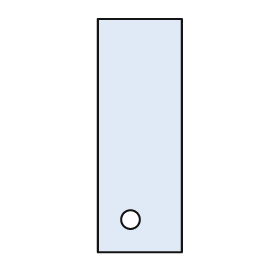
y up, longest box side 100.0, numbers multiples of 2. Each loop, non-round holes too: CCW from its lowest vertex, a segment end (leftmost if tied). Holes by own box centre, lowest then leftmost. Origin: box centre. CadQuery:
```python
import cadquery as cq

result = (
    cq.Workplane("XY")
    .moveTo(-18.0, -50.0)
    .lineTo(18.0, -50.0)
    .lineTo(18.0, 50.0)
    .lineTo(-18.0, 50.0)
    .close()
    .moveTo(-4.0, -36.0)
    .circle(4.0)
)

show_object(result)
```